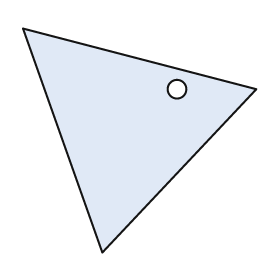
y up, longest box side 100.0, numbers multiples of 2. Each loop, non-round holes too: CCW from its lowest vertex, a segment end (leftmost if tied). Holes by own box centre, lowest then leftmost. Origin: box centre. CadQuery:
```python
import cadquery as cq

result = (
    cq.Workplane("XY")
    .moveTo(-16.0, -48.0)
    .lineTo(50.0, 22.0)
    .lineTo(-50.0, 48.0)
    .close()
    .moveTo(16.0, 22.0)
    .circle(4.0)
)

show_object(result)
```